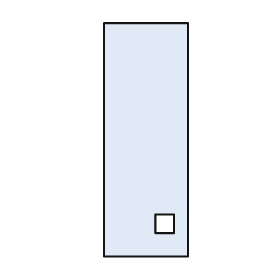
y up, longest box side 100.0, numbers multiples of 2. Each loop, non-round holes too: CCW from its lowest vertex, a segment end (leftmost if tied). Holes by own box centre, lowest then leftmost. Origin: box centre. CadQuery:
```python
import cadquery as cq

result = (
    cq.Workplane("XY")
    .moveTo(-18.0, -50.0)
    .lineTo(18.0, -50.0)
    .lineTo(18.0, 50.0)
    .lineTo(-18.0, 50.0)
    .close()
    .moveTo(4.0, -40.0)
    .lineTo(12.0, -40.0)
    .lineTo(12.0, -32.0)
    .lineTo(4.0, -32.0)
    .close()
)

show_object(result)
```